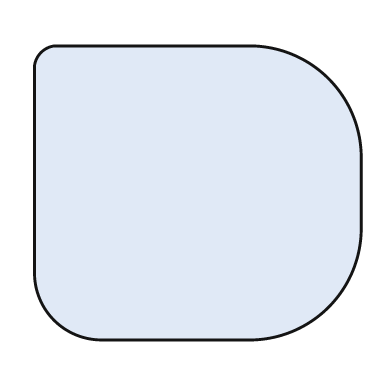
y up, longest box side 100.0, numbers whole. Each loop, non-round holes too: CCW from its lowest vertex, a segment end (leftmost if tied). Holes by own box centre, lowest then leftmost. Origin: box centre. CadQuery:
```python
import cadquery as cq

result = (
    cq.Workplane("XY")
    .moveTo(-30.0, -45.0)
    .lineTo(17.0, -45.0)
    .threePointArc((40.0, -35.0), (50.0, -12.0))
    .lineTo(50.0, 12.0)
    .threePointArc((40.0, 35.0), (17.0, 45.0))
    .lineTo(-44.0, 45.0)
    .threePointArc((-48.0, 43.0), (-50.0, 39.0))
    .lineTo(-50.0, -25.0)
    .threePointArc((-44.0, -39.0), (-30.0, -45.0))
    .close()
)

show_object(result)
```